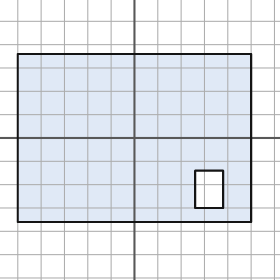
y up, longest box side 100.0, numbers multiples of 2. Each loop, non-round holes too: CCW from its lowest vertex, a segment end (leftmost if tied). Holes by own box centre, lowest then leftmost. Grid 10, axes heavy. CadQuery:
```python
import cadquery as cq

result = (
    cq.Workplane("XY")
    .moveTo(-50.0, -36.0)
    .lineTo(50.0, -36.0)
    .lineTo(50.0, 36.0)
    .lineTo(-50.0, 36.0)
    .close()
    .moveTo(26.0, -30.0)
    .lineTo(38.0, -30.0)
    .lineTo(38.0, -14.0)
    .lineTo(26.0, -14.0)
    .close()
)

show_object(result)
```